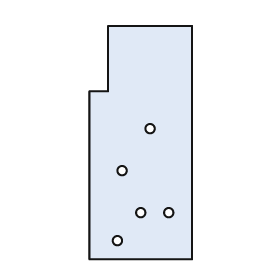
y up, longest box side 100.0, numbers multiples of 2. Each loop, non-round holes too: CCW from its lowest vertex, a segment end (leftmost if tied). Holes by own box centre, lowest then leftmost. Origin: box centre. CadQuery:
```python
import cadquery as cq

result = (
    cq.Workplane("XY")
    .moveTo(-22.0, -50.0)
    .lineTo(22.0, -50.0)
    .lineTo(22.0, 50.0)
    .lineTo(-14.0, 50.0)
    .lineTo(-14.0, 22.0)
    .lineTo(-22.0, 22.0)
    .close()
    .moveTo(-10.0, -42.0)
    .circle(2.0)
    .moveTo(0.0, -30.0)
    .circle(2.0)
    .moveTo(12.0, -30.0)
    .circle(2.0)
    .moveTo(-8.0, -12.0)
    .circle(2.0)
    .moveTo(4.0, 6.0)
    .circle(2.0)
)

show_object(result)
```